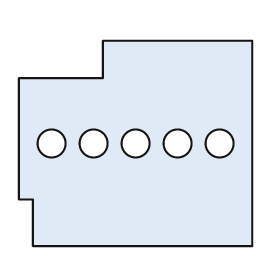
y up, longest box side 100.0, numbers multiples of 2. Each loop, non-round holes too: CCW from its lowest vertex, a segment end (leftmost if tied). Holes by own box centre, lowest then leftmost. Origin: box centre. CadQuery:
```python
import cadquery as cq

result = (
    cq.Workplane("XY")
    .moveTo(-44.0, -44.0)
    .lineTo(50.0, -44.0)
    .lineTo(50.0, 44.0)
    .lineTo(-14.0, 44.0)
    .lineTo(-14.0, 28.0)
    .lineTo(-50.0, 28.0)
    .lineTo(-50.0, -24.0)
    .lineTo(-44.0, -24.0)
    .close()
    .moveTo(-36.0, 0.0)
    .circle(6.0)
    .moveTo(-18.0, 0.0)
    .circle(6.0)
    .moveTo(0.0, 0.0)
    .circle(6.0)
    .moveTo(18.0, 0.0)
    .circle(6.0)
    .moveTo(36.0, 0.0)
    .circle(6.0)
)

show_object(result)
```